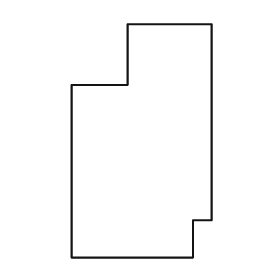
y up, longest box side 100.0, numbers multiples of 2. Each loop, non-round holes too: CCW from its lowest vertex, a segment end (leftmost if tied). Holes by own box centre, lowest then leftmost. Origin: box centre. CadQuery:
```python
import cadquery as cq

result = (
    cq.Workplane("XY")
    .moveTo(-30.0, -50.0)
    .lineTo(22.0, -50.0)
    .lineTo(22.0, -34.0)
    .lineTo(30.0, -34.0)
    .lineTo(30.0, 50.0)
    .lineTo(-6.0, 50.0)
    .lineTo(-6.0, 24.0)
    .lineTo(-30.0, 24.0)
    .close()
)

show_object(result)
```